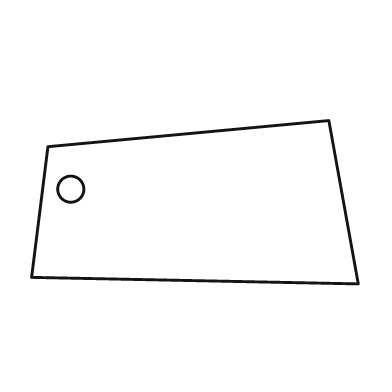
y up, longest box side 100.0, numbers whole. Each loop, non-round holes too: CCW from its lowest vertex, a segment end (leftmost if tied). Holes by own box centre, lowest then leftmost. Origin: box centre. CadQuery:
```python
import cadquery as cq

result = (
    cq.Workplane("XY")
    .moveTo(50.0, -25.0)
    .lineTo(41.0, 25.0)
    .lineTo(-45.0, 17.0)
    .lineTo(-50.0, -23.0)
    .close()
    .moveTo(-38.0, 4.0)
    .circle(4.0)
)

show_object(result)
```